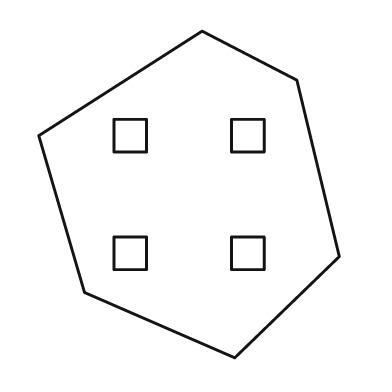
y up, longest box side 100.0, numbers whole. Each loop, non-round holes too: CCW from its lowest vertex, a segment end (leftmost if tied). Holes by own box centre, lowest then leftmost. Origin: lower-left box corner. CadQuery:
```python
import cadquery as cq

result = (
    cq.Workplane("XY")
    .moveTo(60.0, 0.0)
    .lineTo(92.0, 31.0)
    .lineTo(79.0, 85.0)
    .lineTo(50.0, 100.0)
    .lineTo(0.0, 68.0)
    .lineTo(14.0, 20.0)
    .close()
    .moveTo(23.0, 27.0)
    .lineTo(33.0, 27.0)
    .lineTo(33.0, 37.0)
    .lineTo(23.0, 37.0)
    .close()
    .moveTo(59.0, 27.0)
    .lineTo(69.0, 27.0)
    .lineTo(69.0, 37.0)
    .lineTo(59.0, 37.0)
    .close()
    .moveTo(23.0, 63.0)
    .lineTo(33.0, 63.0)
    .lineTo(33.0, 73.0)
    .lineTo(23.0, 73.0)
    .close()
    .moveTo(59.0, 63.0)
    .lineTo(69.0, 63.0)
    .lineTo(69.0, 73.0)
    .lineTo(59.0, 73.0)
    .close()
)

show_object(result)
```